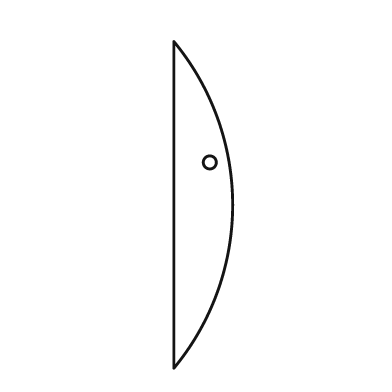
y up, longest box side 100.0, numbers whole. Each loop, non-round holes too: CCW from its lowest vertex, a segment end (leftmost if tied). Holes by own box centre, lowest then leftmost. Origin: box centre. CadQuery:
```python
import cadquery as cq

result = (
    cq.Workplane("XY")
    .moveTo(-9.0, -50.0)
    .threePointArc((9.0, 0.0), (-9.0, 50.0))
    .close()
    .moveTo(2.0, 13.0)
    .circle(2.0)
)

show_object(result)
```